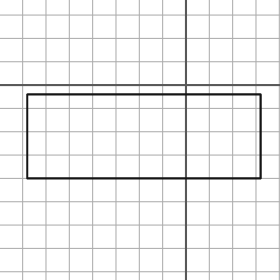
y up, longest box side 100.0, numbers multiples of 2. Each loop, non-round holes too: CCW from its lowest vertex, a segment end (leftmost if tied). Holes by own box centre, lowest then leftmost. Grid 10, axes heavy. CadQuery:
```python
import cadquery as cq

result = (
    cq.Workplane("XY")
    .moveTo(-68.0, -40.0)
    .lineTo(32.0, -40.0)
    .lineTo(32.0, -4.0)
    .lineTo(-68.0, -4.0)
    .close()
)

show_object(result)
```